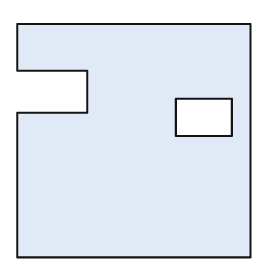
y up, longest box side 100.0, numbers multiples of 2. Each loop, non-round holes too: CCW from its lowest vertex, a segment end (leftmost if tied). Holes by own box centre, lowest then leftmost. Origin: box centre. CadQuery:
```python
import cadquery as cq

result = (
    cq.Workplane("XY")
    .moveTo(-50.0, -50.0)
    .lineTo(50.0, -50.0)
    .lineTo(50.0, 50.0)
    .lineTo(-50.0, 50.0)
    .lineTo(-50.0, 30.0)
    .lineTo(-20.0, 30.0)
    .lineTo(-20.0, 12.0)
    .lineTo(-50.0, 12.0)
    .close()
    .moveTo(18.0, 2.0)
    .lineTo(42.0, 2.0)
    .lineTo(42.0, 18.0)
    .lineTo(18.0, 18.0)
    .close()
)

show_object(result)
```